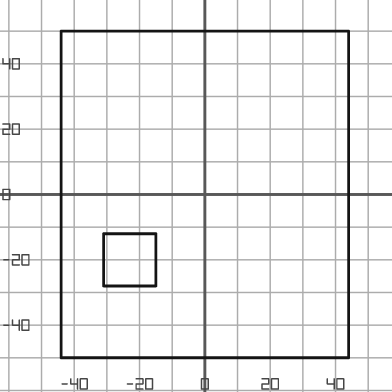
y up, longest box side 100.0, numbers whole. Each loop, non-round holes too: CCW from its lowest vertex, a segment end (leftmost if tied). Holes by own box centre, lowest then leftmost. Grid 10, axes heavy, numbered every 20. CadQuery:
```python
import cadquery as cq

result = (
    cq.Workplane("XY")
    .moveTo(-44.0, -50.0)
    .lineTo(44.0, -50.0)
    .lineTo(44.0, 50.0)
    .lineTo(-44.0, 50.0)
    .close()
    .moveTo(-31.0, -28.0)
    .lineTo(-15.0, -28.0)
    .lineTo(-15.0, -12.0)
    .lineTo(-31.0, -12.0)
    .close()
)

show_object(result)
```